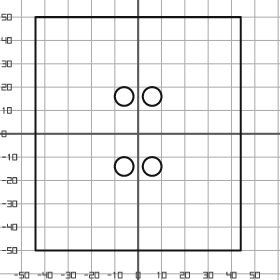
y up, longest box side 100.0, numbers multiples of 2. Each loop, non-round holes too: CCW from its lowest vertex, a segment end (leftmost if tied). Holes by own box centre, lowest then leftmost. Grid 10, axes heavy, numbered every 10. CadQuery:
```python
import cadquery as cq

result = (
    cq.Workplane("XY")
    .moveTo(-44.0, -50.0)
    .lineTo(44.0, -50.0)
    .lineTo(44.0, 50.0)
    .lineTo(-44.0, 50.0)
    .close()
    .moveTo(-6.0, -14.0)
    .circle(4.0)
    .moveTo(6.0, -14.0)
    .circle(4.0)
    .moveTo(-6.0, 16.0)
    .circle(4.0)
    .moveTo(6.0, 16.0)
    .circle(4.0)
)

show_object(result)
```